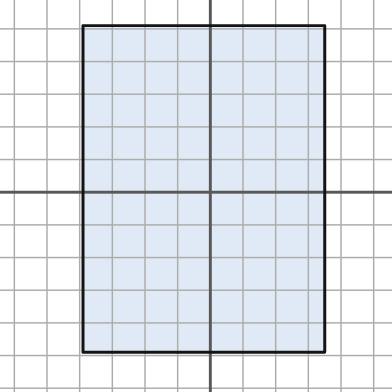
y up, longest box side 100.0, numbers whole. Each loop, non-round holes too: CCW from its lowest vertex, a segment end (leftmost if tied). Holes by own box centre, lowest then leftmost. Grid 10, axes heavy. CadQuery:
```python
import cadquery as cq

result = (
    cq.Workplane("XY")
    .moveTo(-39.0, -49.0)
    .lineTo(35.0, -49.0)
    .lineTo(35.0, 51.0)
    .lineTo(-39.0, 51.0)
    .close()
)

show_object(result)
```